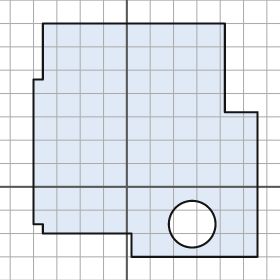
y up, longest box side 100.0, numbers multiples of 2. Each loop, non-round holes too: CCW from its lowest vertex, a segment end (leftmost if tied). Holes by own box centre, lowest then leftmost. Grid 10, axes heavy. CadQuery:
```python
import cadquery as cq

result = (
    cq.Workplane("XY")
    .moveTo(2.0, -30.0)
    .lineTo(56.0, -30.0)
    .lineTo(56.0, 32.0)
    .lineTo(42.0, 32.0)
    .lineTo(42.0, 70.0)
    .lineTo(-36.0, 70.0)
    .lineTo(-36.0, 46.0)
    .lineTo(-40.0, 46.0)
    .lineTo(-40.0, -16.0)
    .lineTo(-36.0, -16.0)
    .lineTo(-36.0, -20.0)
    .lineTo(2.0, -20.0)
    .close()
    .moveTo(28.0, -16.0)
    .circle(10.0)
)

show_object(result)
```